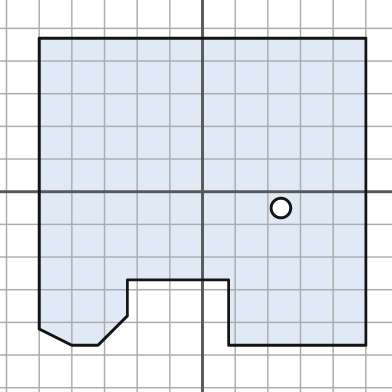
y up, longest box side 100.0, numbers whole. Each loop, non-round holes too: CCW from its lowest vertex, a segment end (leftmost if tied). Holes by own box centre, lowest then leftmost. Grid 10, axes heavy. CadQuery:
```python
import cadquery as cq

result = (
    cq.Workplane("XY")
    .moveTo(-40.0, -47.0)
    .lineTo(-32.0, -47.0)
    .lineTo(-23.0, -38.0)
    .lineTo(-23.0, -27.0)
    .lineTo(8.0, -27.0)
    .lineTo(8.0, -47.0)
    .lineTo(50.0, -47.0)
    .lineTo(50.0, 47.0)
    .lineTo(-50.0, 47.0)
    .lineTo(-50.0, -42.0)
    .close()
    .moveTo(24.0, -5.0)
    .circle(3.0)
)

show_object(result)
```